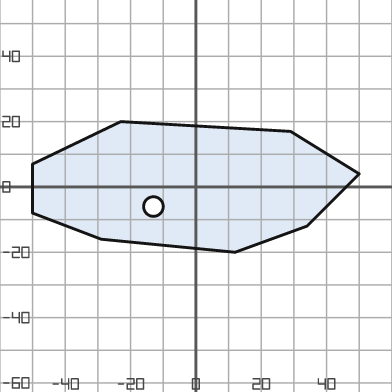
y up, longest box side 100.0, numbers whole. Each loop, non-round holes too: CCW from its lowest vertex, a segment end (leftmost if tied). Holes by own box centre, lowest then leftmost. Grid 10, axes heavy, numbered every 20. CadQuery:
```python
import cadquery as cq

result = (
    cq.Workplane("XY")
    .moveTo(12.0, -20.0)
    .lineTo(34.0, -12.0)
    .lineTo(50.0, 4.0)
    .lineTo(29.0, 17.0)
    .lineTo(-23.0, 20.0)
    .lineTo(-50.0, 7.0)
    .lineTo(-50.0, -8.0)
    .lineTo(-29.0, -16.0)
    .close()
    .moveTo(-13.0, -6.0)
    .circle(3.0)
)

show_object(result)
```